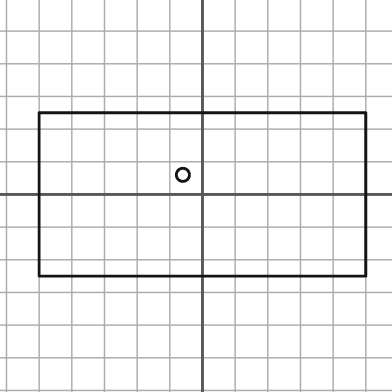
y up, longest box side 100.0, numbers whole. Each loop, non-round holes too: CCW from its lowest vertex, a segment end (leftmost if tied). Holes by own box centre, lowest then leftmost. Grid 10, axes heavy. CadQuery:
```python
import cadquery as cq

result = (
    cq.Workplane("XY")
    .moveTo(-50.0, -25.0)
    .lineTo(50.0, -25.0)
    .lineTo(50.0, 25.0)
    .lineTo(-50.0, 25.0)
    .close()
    .moveTo(-6.0, 6.0)
    .circle(2.0)
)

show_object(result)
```